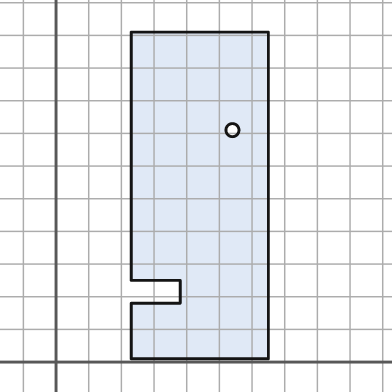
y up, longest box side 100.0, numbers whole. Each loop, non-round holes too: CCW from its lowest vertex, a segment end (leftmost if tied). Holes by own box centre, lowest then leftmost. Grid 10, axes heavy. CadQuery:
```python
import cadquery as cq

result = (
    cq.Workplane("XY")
    .moveTo(23.0, 1.0)
    .lineTo(65.0, 1.0)
    .lineTo(65.0, 101.0)
    .lineTo(23.0, 101.0)
    .lineTo(23.0, 25.0)
    .lineTo(38.0, 25.0)
    .lineTo(38.0, 18.0)
    .lineTo(23.0, 18.0)
    .close()
    .moveTo(54.0, 71.0)
    .circle(2.0)
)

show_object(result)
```